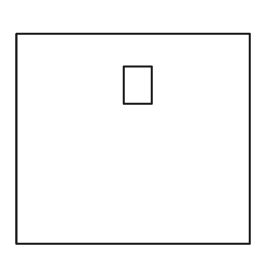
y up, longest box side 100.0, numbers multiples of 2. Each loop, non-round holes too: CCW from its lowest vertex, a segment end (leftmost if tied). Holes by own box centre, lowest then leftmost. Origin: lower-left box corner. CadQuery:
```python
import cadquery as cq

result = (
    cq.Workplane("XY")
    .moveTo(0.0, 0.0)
    .lineTo(100.0, 0.0)
    .lineTo(100.0, 90.0)
    .lineTo(0.0, 90.0)
    .close()
    .moveTo(46.0, 60.0)
    .lineTo(58.0, 60.0)
    .lineTo(58.0, 76.0)
    .lineTo(46.0, 76.0)
    .close()
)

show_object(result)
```